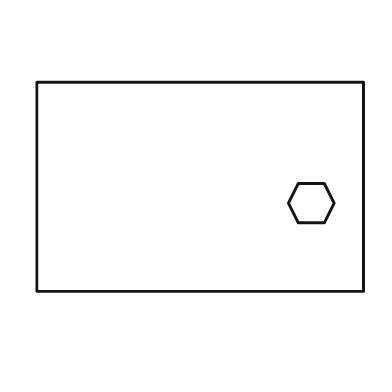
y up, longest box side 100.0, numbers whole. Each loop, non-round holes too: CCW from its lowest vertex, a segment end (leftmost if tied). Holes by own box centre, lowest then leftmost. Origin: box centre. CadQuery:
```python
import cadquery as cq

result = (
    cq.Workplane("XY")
    .moveTo(-50.0, -32.0)
    .lineTo(50.0, -32.0)
    .lineTo(50.0, 32.0)
    .lineTo(-50.0, 32.0)
    .close()
    .moveTo(30.0, -11.0)
    .lineTo(38.0, -11.0)
    .lineTo(41.0, -5.0)
    .lineTo(38.0, 1.0)
    .lineTo(30.0, 1.0)
    .lineTo(27.0, -5.0)
    .close()
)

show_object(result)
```